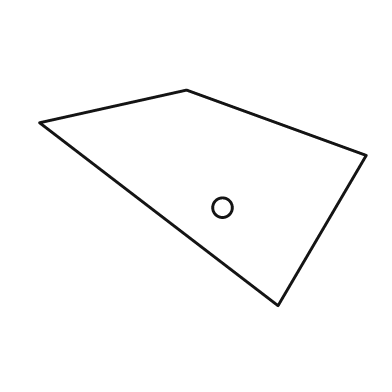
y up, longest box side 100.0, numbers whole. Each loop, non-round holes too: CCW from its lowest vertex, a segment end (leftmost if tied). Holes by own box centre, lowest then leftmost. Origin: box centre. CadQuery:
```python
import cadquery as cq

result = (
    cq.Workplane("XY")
    .moveTo(23.0, -33.0)
    .lineTo(50.0, 13.0)
    .lineTo(-5.0, 33.0)
    .lineTo(-50.0, 23.0)
    .close()
    .moveTo(6.0, -3.0)
    .circle(3.0)
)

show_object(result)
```